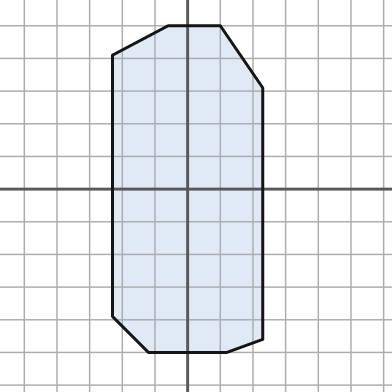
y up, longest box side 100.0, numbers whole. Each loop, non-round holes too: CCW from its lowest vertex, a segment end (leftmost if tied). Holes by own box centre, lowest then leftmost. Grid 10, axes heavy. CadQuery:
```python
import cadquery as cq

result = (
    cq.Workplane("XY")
    .moveTo(-12.0, -50.0)
    .lineTo(12.0, -50.0)
    .lineTo(23.0, -46.0)
    .lineTo(23.0, 31.0)
    .lineTo(10.0, 50.0)
    .lineTo(-6.0, 50.0)
    .lineTo(-23.0, 41.0)
    .lineTo(-23.0, -39.0)
    .close()
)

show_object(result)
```